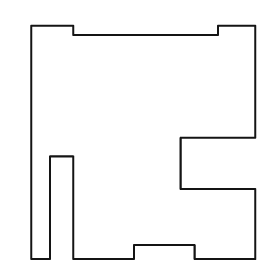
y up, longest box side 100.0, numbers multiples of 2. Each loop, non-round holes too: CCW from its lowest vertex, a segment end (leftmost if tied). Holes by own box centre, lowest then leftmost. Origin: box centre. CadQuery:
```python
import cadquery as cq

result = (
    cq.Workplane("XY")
    .moveTo(-48.0, -50.0)
    .lineTo(-40.0, -50.0)
    .lineTo(-40.0, -6.0)
    .lineTo(-30.0, -6.0)
    .lineTo(-30.0, -50.0)
    .lineTo(-4.0, -50.0)
    .lineTo(-4.0, -44.0)
    .lineTo(22.0, -44.0)
    .lineTo(22.0, -50.0)
    .lineTo(48.0, -50.0)
    .lineTo(48.0, -20.0)
    .lineTo(16.0, -20.0)
    .lineTo(16.0, 2.0)
    .lineTo(48.0, 2.0)
    .lineTo(48.0, 50.0)
    .lineTo(32.0, 50.0)
    .lineTo(32.0, 46.0)
    .lineTo(-30.0, 46.0)
    .lineTo(-30.0, 50.0)
    .lineTo(-48.0, 50.0)
    .close()
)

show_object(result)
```